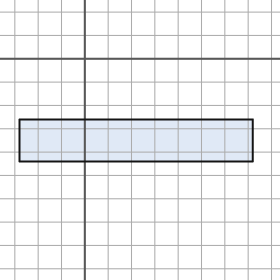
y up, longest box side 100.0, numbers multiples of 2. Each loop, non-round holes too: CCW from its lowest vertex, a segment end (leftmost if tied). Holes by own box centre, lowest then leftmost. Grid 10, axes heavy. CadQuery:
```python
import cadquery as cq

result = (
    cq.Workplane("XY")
    .moveTo(-28.0, -44.0)
    .lineTo(72.0, -44.0)
    .lineTo(72.0, -26.0)
    .lineTo(-28.0, -26.0)
    .close()
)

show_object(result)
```